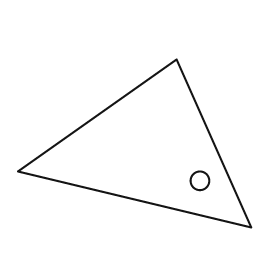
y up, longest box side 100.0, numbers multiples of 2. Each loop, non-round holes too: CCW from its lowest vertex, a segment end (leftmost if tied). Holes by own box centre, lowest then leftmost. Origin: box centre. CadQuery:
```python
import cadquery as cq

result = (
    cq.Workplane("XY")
    .moveTo(50.0, -36.0)
    .lineTo(18.0, 36.0)
    .lineTo(-50.0, -12.0)
    .close()
    .moveTo(28.0, -16.0)
    .circle(4.0)
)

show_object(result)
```